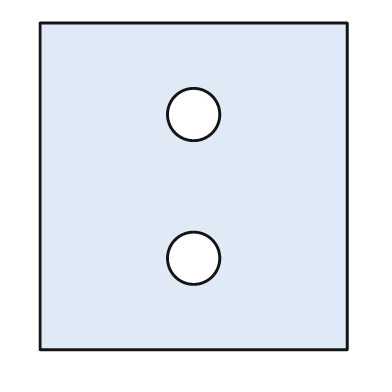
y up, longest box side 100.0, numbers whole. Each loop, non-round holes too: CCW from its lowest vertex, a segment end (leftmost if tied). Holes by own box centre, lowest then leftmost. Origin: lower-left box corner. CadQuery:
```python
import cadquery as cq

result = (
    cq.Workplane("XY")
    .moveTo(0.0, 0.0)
    .lineTo(94.0, 0.0)
    .lineTo(94.0, 100.0)
    .lineTo(0.0, 100.0)
    .close()
    .moveTo(47.0, 28.0)
    .circle(8.0)
    .moveTo(47.0, 72.0)
    .circle(8.0)
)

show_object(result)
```